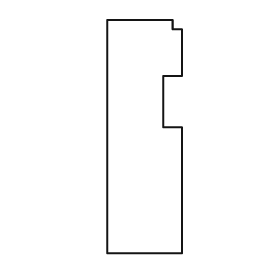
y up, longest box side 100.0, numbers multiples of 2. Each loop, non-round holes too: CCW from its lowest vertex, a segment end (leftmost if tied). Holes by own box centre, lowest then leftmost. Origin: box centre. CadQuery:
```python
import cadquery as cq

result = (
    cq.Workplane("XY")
    .moveTo(-16.0, -50.0)
    .lineTo(16.0, -50.0)
    .lineTo(16.0, 4.0)
    .lineTo(8.0, 4.0)
    .lineTo(8.0, 26.0)
    .lineTo(16.0, 26.0)
    .lineTo(16.0, 46.0)
    .lineTo(12.0, 46.0)
    .lineTo(12.0, 50.0)
    .lineTo(-16.0, 50.0)
    .close()
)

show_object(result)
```